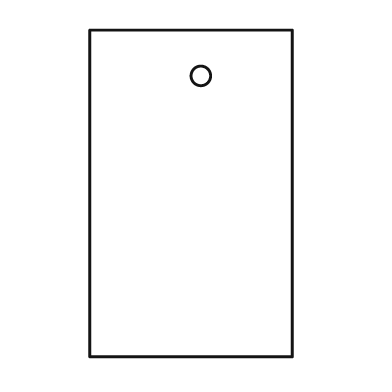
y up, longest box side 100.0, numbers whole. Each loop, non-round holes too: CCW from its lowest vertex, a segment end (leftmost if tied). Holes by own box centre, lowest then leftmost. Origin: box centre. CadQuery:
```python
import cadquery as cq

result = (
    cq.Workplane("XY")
    .moveTo(-31.0, -50.0)
    .lineTo(31.0, -50.0)
    .lineTo(31.0, 50.0)
    .lineTo(-31.0, 50.0)
    .close()
    .moveTo(3.0, 36.0)
    .circle(3.0)
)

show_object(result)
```